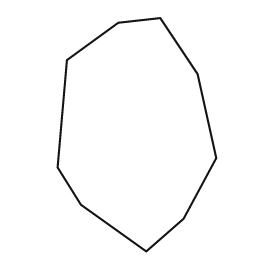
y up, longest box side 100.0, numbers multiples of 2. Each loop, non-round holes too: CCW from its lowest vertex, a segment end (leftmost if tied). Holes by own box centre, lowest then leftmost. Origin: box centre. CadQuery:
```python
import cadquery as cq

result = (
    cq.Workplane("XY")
    .moveTo(4.0, -50.0)
    .lineTo(20.0, -36.0)
    .lineTo(34.0, -10.0)
    .lineTo(26.0, 26.0)
    .lineTo(10.0, 50.0)
    .lineTo(-8.0, 48.0)
    .lineTo(-30.0, 32.0)
    .lineTo(-34.0, -14.0)
    .lineTo(-24.0, -30.0)
    .close()
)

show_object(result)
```